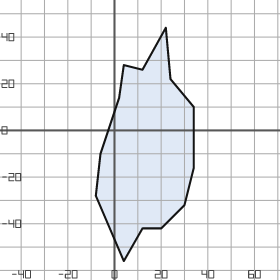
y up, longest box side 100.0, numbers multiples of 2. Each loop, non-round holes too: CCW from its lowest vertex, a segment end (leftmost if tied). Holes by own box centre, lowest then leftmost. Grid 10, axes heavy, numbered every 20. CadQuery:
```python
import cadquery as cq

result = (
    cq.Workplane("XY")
    .moveTo(4.0, -56.0)
    .lineTo(12.0, -42.0)
    .lineTo(20.0, -42.0)
    .lineTo(30.0, -32.0)
    .lineTo(34.0, -16.0)
    .lineTo(34.0, 10.0)
    .lineTo(24.0, 22.0)
    .lineTo(22.0, 44.0)
    .lineTo(12.0, 26.0)
    .lineTo(4.0, 28.0)
    .lineTo(2.0, 14.0)
    .lineTo(-6.0, -10.0)
    .lineTo(-8.0, -28.0)
    .close()
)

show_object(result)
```